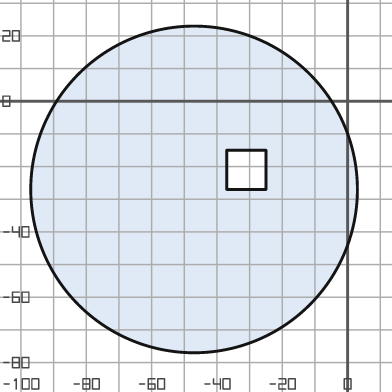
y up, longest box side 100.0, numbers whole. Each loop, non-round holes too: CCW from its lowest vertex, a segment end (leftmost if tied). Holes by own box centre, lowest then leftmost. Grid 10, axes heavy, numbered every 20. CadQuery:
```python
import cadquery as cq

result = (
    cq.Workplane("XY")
    .moveTo(-47.0, -27.0)
    .circle(50.0)
    .moveTo(-37.0, -27.0)
    .lineTo(-25.0, -27.0)
    .lineTo(-25.0, -15.0)
    .lineTo(-37.0, -15.0)
    .close()
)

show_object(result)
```